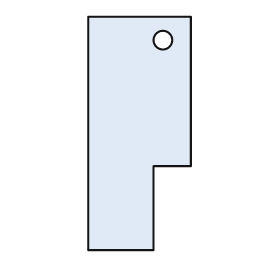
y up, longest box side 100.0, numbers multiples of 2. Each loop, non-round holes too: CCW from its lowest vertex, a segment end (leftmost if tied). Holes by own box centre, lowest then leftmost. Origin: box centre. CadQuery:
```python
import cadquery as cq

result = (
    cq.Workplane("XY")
    .moveTo(-22.0, -50.0)
    .lineTo(6.0, -50.0)
    .lineTo(6.0, -14.0)
    .lineTo(22.0, -14.0)
    .lineTo(22.0, 50.0)
    .lineTo(-22.0, 50.0)
    .close()
    .moveTo(10.0, 40.0)
    .circle(4.0)
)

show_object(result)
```